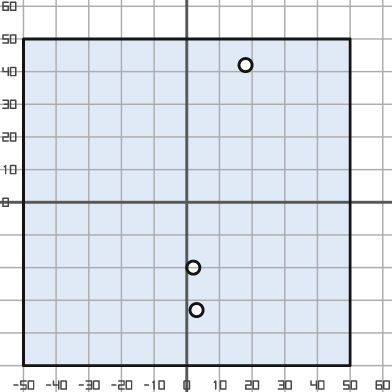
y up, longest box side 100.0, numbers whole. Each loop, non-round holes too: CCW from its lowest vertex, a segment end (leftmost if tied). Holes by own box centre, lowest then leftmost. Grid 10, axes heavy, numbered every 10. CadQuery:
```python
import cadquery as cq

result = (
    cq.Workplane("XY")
    .moveTo(-50.0, -50.0)
    .lineTo(50.0, -50.0)
    .lineTo(50.0, 50.0)
    .lineTo(-50.0, 50.0)
    .close()
    .moveTo(3.0, -33.0)
    .circle(2.0)
    .moveTo(2.0, -20.0)
    .circle(2.0)
    .moveTo(18.0, 42.0)
    .circle(2.0)
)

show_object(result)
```